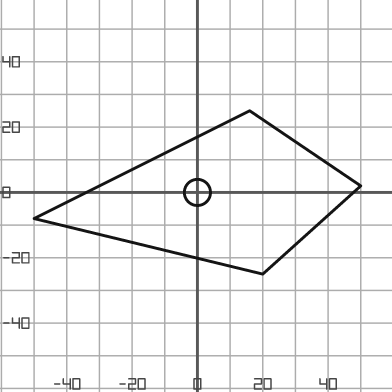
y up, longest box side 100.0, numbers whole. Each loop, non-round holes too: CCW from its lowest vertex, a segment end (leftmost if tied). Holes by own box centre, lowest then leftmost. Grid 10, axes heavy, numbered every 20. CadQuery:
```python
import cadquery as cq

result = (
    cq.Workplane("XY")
    .moveTo(20.0, -25.0)
    .lineTo(50.0, 2.0)
    .lineTo(16.0, 25.0)
    .lineTo(-50.0, -8.0)
    .close()
    .moveTo(0.0, 0.0)
    .circle(4.0)
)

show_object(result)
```